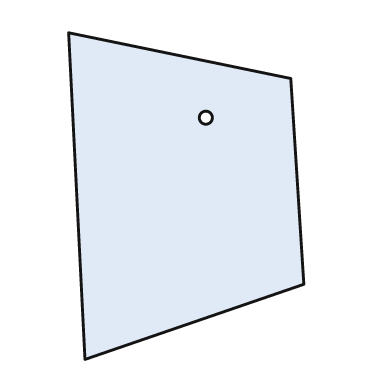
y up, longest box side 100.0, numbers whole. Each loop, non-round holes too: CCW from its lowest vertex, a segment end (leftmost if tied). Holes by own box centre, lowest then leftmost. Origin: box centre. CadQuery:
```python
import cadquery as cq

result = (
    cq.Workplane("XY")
    .moveTo(-31.0, -50.0)
    .lineTo(36.0, -27.0)
    .lineTo(32.0, 36.0)
    .lineTo(-36.0, 50.0)
    .close()
    .moveTo(6.0, 24.0)
    .circle(2.0)
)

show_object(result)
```